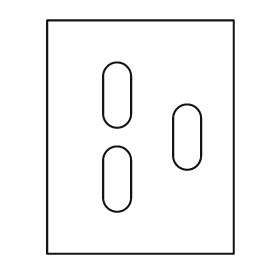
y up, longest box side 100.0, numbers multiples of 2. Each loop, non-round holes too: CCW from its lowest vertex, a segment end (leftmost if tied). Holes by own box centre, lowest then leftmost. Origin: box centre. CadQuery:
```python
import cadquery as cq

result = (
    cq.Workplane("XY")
    .moveTo(-40.0, -50.0)
    .lineTo(40.0, -50.0)
    .lineTo(40.0, 50.0)
    .lineTo(-40.0, 50.0)
    .close()
    .moveTo(-16.0, -26.0)
    .threePointArc((-10.0, -32.0), (-4.0, -26.0))
    .lineTo(-4.0, -10.0)
    .threePointArc((-10.0, -4.0), (-16.0, -10.0))
    .close()
    .moveTo(14.0, -8.0)
    .threePointArc((20.0, -14.0), (26.0, -8.0))
    .lineTo(26.0, 8.0)
    .threePointArc((20.0, 14.0), (14.0, 8.0))
    .close()
    .moveTo(-16.0, 10.0)
    .threePointArc((-10.0, 4.0), (-4.0, 10.0))
    .lineTo(-4.0, 26.0)
    .threePointArc((-10.0, 32.0), (-16.0, 26.0))
    .close()
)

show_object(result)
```